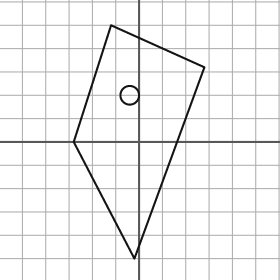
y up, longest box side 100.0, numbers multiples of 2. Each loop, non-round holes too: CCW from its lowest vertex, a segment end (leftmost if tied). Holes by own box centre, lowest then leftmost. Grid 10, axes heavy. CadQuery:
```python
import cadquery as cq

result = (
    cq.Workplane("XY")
    .moveTo(-2.0, -50.0)
    .lineTo(28.0, 32.0)
    .lineTo(-12.0, 50.0)
    .lineTo(-28.0, 0.0)
    .close()
    .moveTo(-4.0, 20.0)
    .circle(4.0)
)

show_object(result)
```